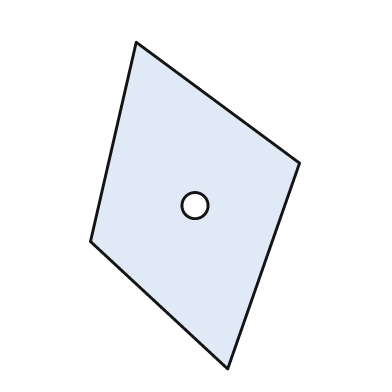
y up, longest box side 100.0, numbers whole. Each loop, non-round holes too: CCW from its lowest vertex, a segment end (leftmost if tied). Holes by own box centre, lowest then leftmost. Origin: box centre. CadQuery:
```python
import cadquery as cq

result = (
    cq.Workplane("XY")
    .moveTo(10.0, -50.0)
    .lineTo(32.0, 13.0)
    .lineTo(-18.0, 50.0)
    .lineTo(-32.0, -11.0)
    .close()
    .moveTo(0.0, 0.0)
    .circle(4.0)
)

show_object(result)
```